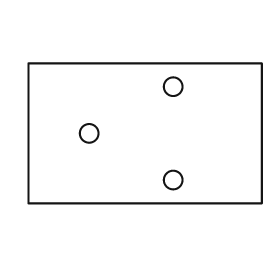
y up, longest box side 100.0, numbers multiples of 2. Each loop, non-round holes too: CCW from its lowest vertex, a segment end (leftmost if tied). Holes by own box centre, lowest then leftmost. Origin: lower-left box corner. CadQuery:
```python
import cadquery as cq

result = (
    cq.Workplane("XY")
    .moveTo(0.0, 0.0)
    .lineTo(100.0, 0.0)
    .lineTo(100.0, 60.0)
    .lineTo(0.0, 60.0)
    .close()
    .moveTo(62.0, 10.0)
    .circle(4.0)
    .moveTo(26.0, 30.0)
    .circle(4.0)
    .moveTo(62.0, 50.0)
    .circle(4.0)
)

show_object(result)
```